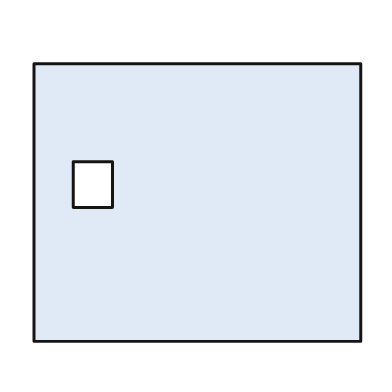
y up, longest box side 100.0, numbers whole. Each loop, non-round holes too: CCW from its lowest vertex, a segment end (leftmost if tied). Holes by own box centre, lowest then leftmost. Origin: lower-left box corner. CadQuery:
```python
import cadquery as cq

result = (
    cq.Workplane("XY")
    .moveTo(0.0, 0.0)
    .lineTo(100.0, 0.0)
    .lineTo(100.0, 85.0)
    .lineTo(0.0, 85.0)
    .close()
    .moveTo(12.0, 41.0)
    .lineTo(24.0, 41.0)
    .lineTo(24.0, 55.0)
    .lineTo(12.0, 55.0)
    .close()
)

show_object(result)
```